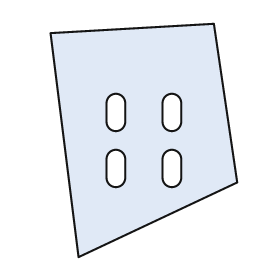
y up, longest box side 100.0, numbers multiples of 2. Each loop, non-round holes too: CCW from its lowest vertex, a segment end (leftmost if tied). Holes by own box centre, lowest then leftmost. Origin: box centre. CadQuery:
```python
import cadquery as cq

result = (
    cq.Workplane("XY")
    .moveTo(-28.0, -50.0)
    .lineTo(40.0, -18.0)
    .lineTo(30.0, 50.0)
    .lineTo(-40.0, 46.0)
    .close()
    .moveTo(-16.0, -16.0)
    .threePointArc((-12.0, -20.0), (-8.0, -16.0))
    .lineTo(-8.0, -8.0)
    .threePointArc((-12.0, -4.0), (-16.0, -8.0))
    .close()
    .moveTo(8.0, -16.0)
    .threePointArc((12.0, -20.0), (16.0, -16.0))
    .lineTo(16.0, -8.0)
    .threePointArc((12.0, -4.0), (8.0, -8.0))
    .close()
    .moveTo(-16.0, 8.0)
    .threePointArc((-12.0, 4.0), (-8.0, 8.0))
    .lineTo(-8.0, 16.0)
    .threePointArc((-12.0, 20.0), (-16.0, 16.0))
    .close()
    .moveTo(8.0, 8.0)
    .threePointArc((12.0, 4.0), (16.0, 8.0))
    .lineTo(16.0, 16.0)
    .threePointArc((12.0, 20.0), (8.0, 16.0))
    .close()
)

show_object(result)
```